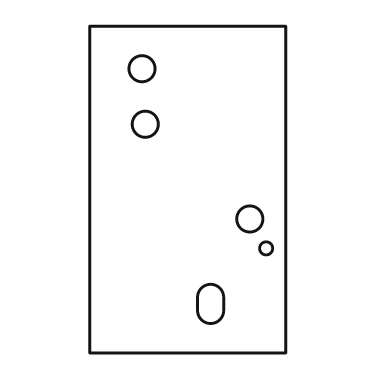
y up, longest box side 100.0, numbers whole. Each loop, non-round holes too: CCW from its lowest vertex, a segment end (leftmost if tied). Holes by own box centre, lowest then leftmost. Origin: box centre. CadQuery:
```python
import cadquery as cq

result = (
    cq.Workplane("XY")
    .moveTo(-30.0, -50.0)
    .lineTo(30.0, -50.0)
    .lineTo(30.0, 50.0)
    .lineTo(-30.0, 50.0)
    .close()
    .moveTo(3.0, -37.0)
    .threePointArc((7.0, -41.0), (11.0, -37.0))
    .lineTo(11.0, -33.0)
    .threePointArc((7.0, -29.0), (3.0, -33.0))
    .close()
    .moveTo(24.0, -18.0)
    .circle(2.0)
    .moveTo(19.0, -9.0)
    .circle(4.0)
    .moveTo(-13.0, 20.0)
    .circle(4.0)
    .moveTo(-14.0, 37.0)
    .circle(4.0)
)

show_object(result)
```